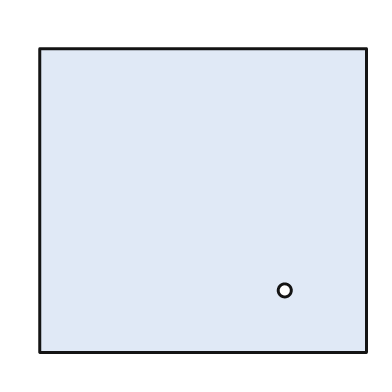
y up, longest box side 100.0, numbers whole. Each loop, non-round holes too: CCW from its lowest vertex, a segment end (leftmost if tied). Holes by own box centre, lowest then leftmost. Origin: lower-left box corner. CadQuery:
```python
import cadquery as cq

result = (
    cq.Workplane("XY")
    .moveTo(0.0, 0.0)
    .lineTo(100.0, 0.0)
    .lineTo(100.0, 93.0)
    .lineTo(0.0, 93.0)
    .close()
    .moveTo(75.0, 19.0)
    .circle(2.0)
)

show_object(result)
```